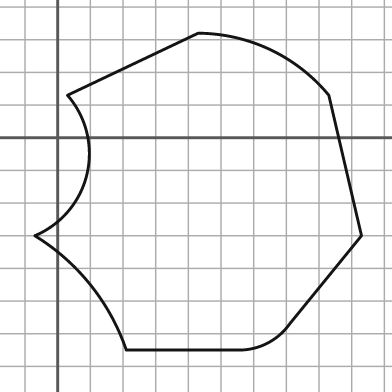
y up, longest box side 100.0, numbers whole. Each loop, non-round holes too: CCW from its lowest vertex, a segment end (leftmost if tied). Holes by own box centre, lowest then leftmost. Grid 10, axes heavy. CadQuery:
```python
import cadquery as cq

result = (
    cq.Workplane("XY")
    .moveTo(21.0, -65.0)
    .lineTo(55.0, -65.0)
    .threePointArc((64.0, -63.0), (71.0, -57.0))
    .lineTo(93.0, -30.0)
    .lineTo(83.0, 13.0)
    .threePointArc((65.0, 27.0), (43.0, 32.0))
    .lineTo(3.0, 13.0)
    .threePointArc((9.0, -11.0), (-7.0, -30.0))
    .threePointArc((10.0, -45.0), (21.0, -65.0))
    .close()
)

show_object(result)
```